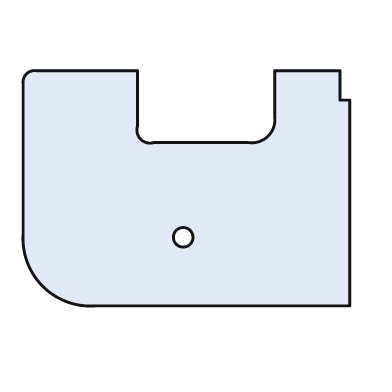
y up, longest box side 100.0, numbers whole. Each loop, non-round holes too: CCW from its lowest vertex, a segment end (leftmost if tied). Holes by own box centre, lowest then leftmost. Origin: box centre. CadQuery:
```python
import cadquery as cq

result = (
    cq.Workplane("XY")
    .moveTo(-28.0, -36.0)
    .lineTo(50.0, -36.0)
    .lineTo(50.0, 27.0)
    .lineTo(47.0, 27.0)
    .lineTo(47.0, 36.0)
    .lineTo(27.0, 36.0)
    .lineTo(27.0, 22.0)
    .threePointArc((25.0, 16.0), (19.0, 14.0))
    .lineTo(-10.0, 14.0)
    .threePointArc((-14.0, 15.0), (-15.0, 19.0))
    .lineTo(-15.0, 36.0)
    .lineTo(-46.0, 36.0)
    .threePointArc((-49.0, 35.0), (-50.0, 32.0))
    .lineTo(-50.0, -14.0)
    .threePointArc((-44.0, -30.0), (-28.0, -36.0))
    .close()
    .moveTo(-1.0, -15.0)
    .circle(3.0)
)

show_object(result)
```